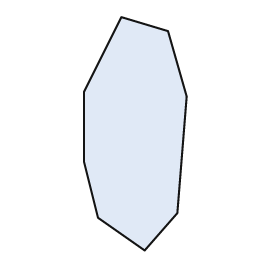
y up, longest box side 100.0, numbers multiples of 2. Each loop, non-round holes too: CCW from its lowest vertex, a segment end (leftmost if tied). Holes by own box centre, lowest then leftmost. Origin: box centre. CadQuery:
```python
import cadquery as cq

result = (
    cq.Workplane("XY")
    .moveTo(4.0, -50.0)
    .lineTo(18.0, -34.0)
    .lineTo(22.0, 16.0)
    .lineTo(14.0, 44.0)
    .lineTo(-6.0, 50.0)
    .lineTo(-22.0, 18.0)
    .lineTo(-22.0, -12.0)
    .lineTo(-16.0, -36.0)
    .close()
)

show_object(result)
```